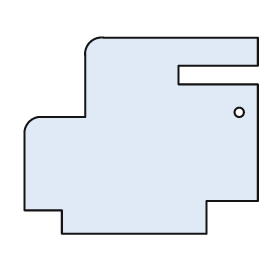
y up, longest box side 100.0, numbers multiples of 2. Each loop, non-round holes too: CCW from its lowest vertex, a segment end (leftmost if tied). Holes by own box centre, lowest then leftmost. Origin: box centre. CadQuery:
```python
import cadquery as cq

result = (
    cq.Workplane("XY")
    .moveTo(-34.0, -42.0)
    .lineTo(28.0, -42.0)
    .lineTo(28.0, -28.0)
    .lineTo(50.0, -28.0)
    .lineTo(50.0, 22.0)
    .lineTo(16.0, 22.0)
    .lineTo(16.0, 30.0)
    .lineTo(50.0, 30.0)
    .lineTo(50.0, 42.0)
    .lineTo(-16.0, 42.0)
    .threePointArc((-22.0, 40.0), (-24.0, 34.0))
    .lineTo(-24.0, 8.0)
    .lineTo(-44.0, 8.0)
    .threePointArc((-48.0, 6.0), (-50.0, 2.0))
    .lineTo(-50.0, -32.0)
    .lineTo(-34.0, -32.0)
    .close()
    .moveTo(42.0, 10.0)
    .circle(2.0)
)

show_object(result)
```